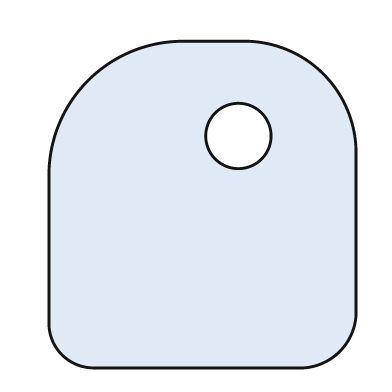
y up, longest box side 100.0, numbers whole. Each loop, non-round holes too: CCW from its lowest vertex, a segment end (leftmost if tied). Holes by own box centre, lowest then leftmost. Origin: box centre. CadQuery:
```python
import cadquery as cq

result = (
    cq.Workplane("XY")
    .moveTo(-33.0, -50.0)
    .lineTo(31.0, -50.0)
    .threePointArc((42.0, -45.0), (47.0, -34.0))
    .lineTo(47.0, 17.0)
    .threePointArc((37.0, 40.0), (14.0, 50.0))
    .lineTo(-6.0, 50.0)
    .threePointArc((-35.0, 38.0), (-47.0, 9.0))
    .lineTo(-47.0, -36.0)
    .threePointArc((-43.0, -46.0), (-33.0, -50.0))
    .close()
    .moveTo(11.0, 21.0)
    .circle(10.0)
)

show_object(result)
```